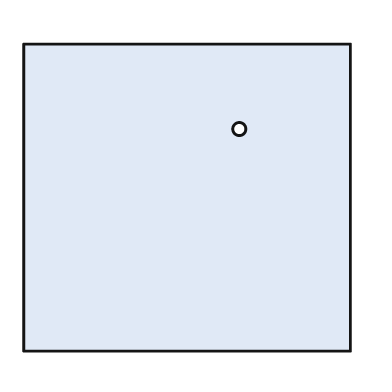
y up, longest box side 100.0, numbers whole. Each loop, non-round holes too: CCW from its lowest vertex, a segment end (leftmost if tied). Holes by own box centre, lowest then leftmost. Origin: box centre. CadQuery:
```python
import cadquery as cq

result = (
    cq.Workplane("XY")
    .moveTo(-50.0, -47.0)
    .lineTo(50.0, -47.0)
    .lineTo(50.0, 47.0)
    .lineTo(-50.0, 47.0)
    .close()
    .moveTo(16.0, 21.0)
    .circle(2.0)
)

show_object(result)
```